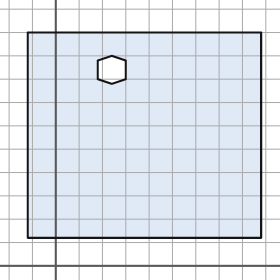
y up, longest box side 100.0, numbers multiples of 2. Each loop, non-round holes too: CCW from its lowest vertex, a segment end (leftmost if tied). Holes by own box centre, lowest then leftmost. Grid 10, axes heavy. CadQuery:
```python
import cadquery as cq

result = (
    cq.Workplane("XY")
    .moveTo(-12.0, 12.0)
    .lineTo(88.0, 12.0)
    .lineTo(88.0, 100.0)
    .lineTo(-12.0, 100.0)
    .close()
    .moveTo(24.0, 78.0)
    .lineTo(30.0, 80.0)
    .lineTo(30.0, 88.0)
    .lineTo(24.0, 90.0)
    .lineTo(18.0, 88.0)
    .lineTo(18.0, 80.0)
    .close()
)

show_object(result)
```